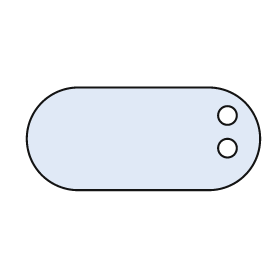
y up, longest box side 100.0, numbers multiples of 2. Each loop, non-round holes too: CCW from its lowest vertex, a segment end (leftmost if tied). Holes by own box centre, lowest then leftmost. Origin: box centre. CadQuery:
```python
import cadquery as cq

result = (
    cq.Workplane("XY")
    .moveTo(-28.0, -22.0)
    .lineTo(28.0, -22.0)
    .threePointArc((50.0, 0.0), (28.0, 22.0))
    .lineTo(-28.0, 22.0)
    .threePointArc((-50.0, 0.0), (-28.0, -22.0))
    .close()
    .moveTo(36.0, -4.0)
    .circle(4.0)
    .moveTo(36.0, 10.0)
    .circle(4.0)
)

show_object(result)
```